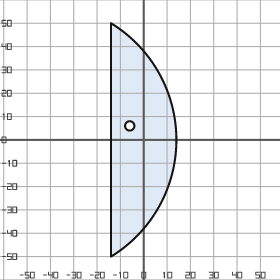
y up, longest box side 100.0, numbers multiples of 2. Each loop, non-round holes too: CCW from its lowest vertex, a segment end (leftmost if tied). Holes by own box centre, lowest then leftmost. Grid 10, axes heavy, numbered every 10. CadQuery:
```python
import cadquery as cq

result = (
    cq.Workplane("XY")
    .moveTo(-14.0, -50.0)
    .threePointArc((14.0, 0.0), (-14.0, 50.0))
    .close()
    .moveTo(-6.0, 6.0)
    .circle(2.0)
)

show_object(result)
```